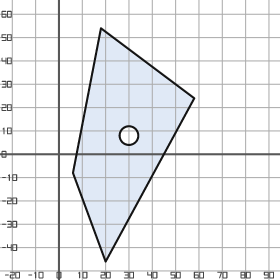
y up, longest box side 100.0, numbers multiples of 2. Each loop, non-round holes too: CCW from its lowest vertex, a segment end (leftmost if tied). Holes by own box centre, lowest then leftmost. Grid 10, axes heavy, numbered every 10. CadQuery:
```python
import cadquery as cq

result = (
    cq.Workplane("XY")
    .moveTo(20.0, -46.0)
    .lineTo(58.0, 24.0)
    .lineTo(18.0, 54.0)
    .lineTo(6.0, -8.0)
    .close()
    .moveTo(30.0, 8.0)
    .circle(4.0)
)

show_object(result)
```